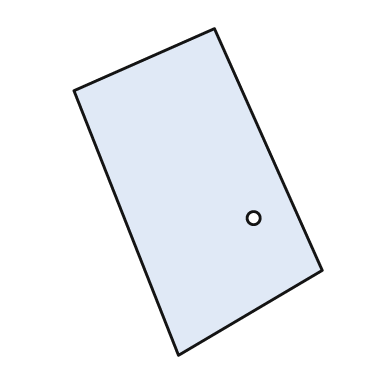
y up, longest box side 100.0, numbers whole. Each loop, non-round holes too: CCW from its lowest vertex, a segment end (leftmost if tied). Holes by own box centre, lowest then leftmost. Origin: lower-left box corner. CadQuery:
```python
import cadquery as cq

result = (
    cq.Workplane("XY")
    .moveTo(32.0, 0.0)
    .lineTo(76.0, 26.0)
    .lineTo(43.0, 100.0)
    .lineTo(0.0, 81.0)
    .close()
    .moveTo(55.0, 42.0)
    .circle(2.0)
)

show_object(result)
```